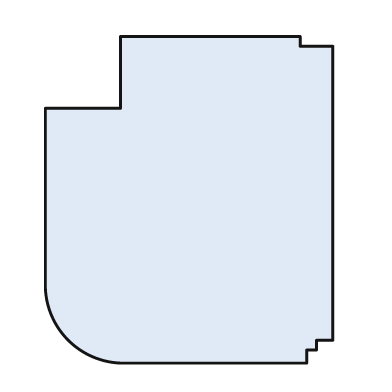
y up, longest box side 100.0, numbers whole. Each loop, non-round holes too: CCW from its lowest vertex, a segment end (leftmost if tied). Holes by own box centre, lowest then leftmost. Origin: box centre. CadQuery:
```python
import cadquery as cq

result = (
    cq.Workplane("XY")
    .moveTo(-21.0, -50.0)
    .lineTo(36.0, -50.0)
    .lineTo(36.0, -46.0)
    .lineTo(39.0, -46.0)
    .lineTo(39.0, -43.0)
    .lineTo(44.0, -43.0)
    .lineTo(44.0, 47.0)
    .lineTo(34.0, 47.0)
    .lineTo(34.0, 50.0)
    .lineTo(-21.0, 50.0)
    .lineTo(-21.0, 28.0)
    .lineTo(-44.0, 28.0)
    .lineTo(-44.0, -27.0)
    .threePointArc((-37.0, -43.0), (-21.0, -50.0))
    .close()
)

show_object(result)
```